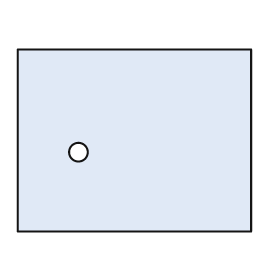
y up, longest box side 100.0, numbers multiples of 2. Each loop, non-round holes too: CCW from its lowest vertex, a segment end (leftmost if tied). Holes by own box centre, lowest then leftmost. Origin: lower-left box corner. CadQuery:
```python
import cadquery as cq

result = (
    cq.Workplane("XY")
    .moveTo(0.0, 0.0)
    .lineTo(100.0, 0.0)
    .lineTo(100.0, 78.0)
    .lineTo(0.0, 78.0)
    .close()
    .moveTo(26.0, 34.0)
    .circle(4.0)
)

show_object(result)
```